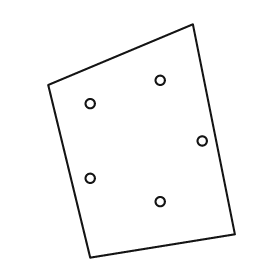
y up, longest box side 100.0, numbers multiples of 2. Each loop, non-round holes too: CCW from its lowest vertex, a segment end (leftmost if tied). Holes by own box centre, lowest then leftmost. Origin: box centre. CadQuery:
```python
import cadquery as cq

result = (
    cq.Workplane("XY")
    .moveTo(-22.0, -50.0)
    .lineTo(40.0, -40.0)
    .lineTo(22.0, 50.0)
    .lineTo(-40.0, 24.0)
    .close()
    .moveTo(8.0, -26.0)
    .circle(2.0)
    .moveTo(-22.0, -16.0)
    .circle(2.0)
    .moveTo(26.0, 0.0)
    .circle(2.0)
    .moveTo(-22.0, 16.0)
    .circle(2.0)
    .moveTo(8.0, 26.0)
    .circle(2.0)
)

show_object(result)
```